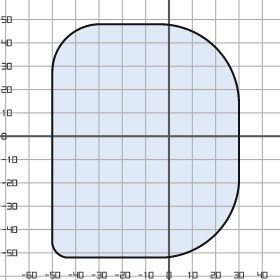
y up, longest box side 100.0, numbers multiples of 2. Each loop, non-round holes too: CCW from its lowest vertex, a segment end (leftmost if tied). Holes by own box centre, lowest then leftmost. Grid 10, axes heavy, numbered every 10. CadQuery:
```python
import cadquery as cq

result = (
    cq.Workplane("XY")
    .moveTo(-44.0, -52.0)
    .lineTo(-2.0, -52.0)
    .threePointArc((20.0, -42.0), (30.0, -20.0))
    .lineTo(30.0, 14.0)
    .threePointArc((20.0, 38.0), (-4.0, 48.0))
    .lineTo(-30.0, 48.0)
    .threePointArc((-44.0, 42.0), (-50.0, 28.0))
    .lineTo(-50.0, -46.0)
    .threePointArc((-48.0, -50.0), (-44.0, -52.0))
    .close()
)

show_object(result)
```